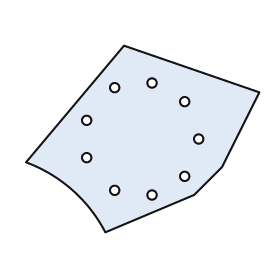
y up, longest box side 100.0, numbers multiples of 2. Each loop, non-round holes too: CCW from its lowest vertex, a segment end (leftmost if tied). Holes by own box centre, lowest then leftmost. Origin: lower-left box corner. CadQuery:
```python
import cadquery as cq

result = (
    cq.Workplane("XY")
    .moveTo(34.0, 0.0)
    .lineTo(72.0, 16.0)
    .lineTo(84.0, 28.0)
    .lineTo(100.0, 60.0)
    .lineTo(42.0, 80.0)
    .lineTo(0.0, 30.0)
    .threePointArc((20.0, 18.0), (34.0, 0.0))
    .close()
    .moveTo(54.0, 16.0)
    .circle(2.0)
    .moveTo(38.0, 18.0)
    .circle(2.0)
    .moveTo(68.0, 24.0)
    .circle(2.0)
    .moveTo(26.0, 32.0)
    .circle(2.0)
    .moveTo(74.0, 40.0)
    .circle(2.0)
    .moveTo(26.0, 48.0)
    .circle(2.0)
    .moveTo(68.0, 56.0)
    .circle(2.0)
    .moveTo(38.0, 62.0)
    .circle(2.0)
    .moveTo(54.0, 64.0)
    .circle(2.0)
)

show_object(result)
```